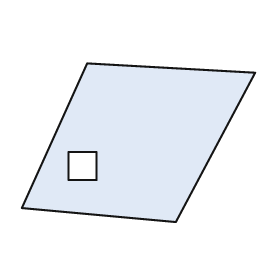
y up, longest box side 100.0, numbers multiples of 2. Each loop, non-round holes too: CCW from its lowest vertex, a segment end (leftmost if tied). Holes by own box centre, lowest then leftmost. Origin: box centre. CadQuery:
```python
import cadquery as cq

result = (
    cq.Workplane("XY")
    .moveTo(16.0, -34.0)
    .lineTo(50.0, 30.0)
    .lineTo(-22.0, 34.0)
    .lineTo(-50.0, -28.0)
    .close()
    .moveTo(-30.0, -16.0)
    .lineTo(-18.0, -16.0)
    .lineTo(-18.0, -4.0)
    .lineTo(-30.0, -4.0)
    .close()
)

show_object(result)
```